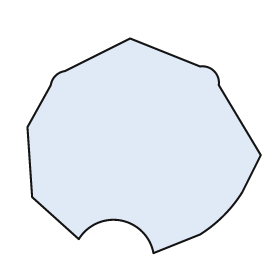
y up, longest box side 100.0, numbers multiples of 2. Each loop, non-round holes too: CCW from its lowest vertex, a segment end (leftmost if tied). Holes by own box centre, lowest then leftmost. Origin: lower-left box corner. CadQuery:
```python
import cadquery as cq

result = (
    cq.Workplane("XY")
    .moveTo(54.0, 0.0)
    .lineTo(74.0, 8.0)
    .threePointArc((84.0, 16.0), (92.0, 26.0))
    .lineTo(100.0, 42.0)
    .lineTo(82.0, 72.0)
    .threePointArc((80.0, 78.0), (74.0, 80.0))
    .lineTo(44.0, 92.0)
    .lineTo(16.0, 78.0)
    .threePointArc((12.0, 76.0), (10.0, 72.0))
    .lineTo(0.0, 54.0)
    .lineTo(2.0, 24.0)
    .lineTo(22.0, 6.0)
    .threePointArc((40.0, 14.0), (54.0, 0.0))
    .close()
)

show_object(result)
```